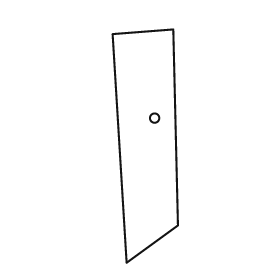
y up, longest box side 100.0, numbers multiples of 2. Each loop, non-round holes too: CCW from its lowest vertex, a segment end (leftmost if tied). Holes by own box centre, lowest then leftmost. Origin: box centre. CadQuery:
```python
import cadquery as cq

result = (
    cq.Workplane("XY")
    .moveTo(-8.0, -50.0)
    .lineTo(14.0, -34.0)
    .lineTo(12.0, 50.0)
    .lineTo(-14.0, 48.0)
    .close()
    .moveTo(4.0, 12.0)
    .circle(2.0)
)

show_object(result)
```